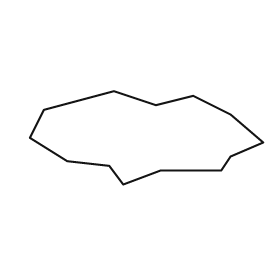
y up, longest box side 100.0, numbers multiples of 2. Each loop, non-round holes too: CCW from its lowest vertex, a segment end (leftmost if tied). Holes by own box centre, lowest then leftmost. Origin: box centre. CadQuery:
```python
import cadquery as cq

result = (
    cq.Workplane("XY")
    .moveTo(-10.0, -20.0)
    .lineTo(6.0, -14.0)
    .lineTo(32.0, -14.0)
    .lineTo(36.0, -8.0)
    .lineTo(50.0, -2.0)
    .lineTo(36.0, 10.0)
    .lineTo(20.0, 18.0)
    .lineTo(4.0, 14.0)
    .lineTo(-14.0, 20.0)
    .lineTo(-44.0, 12.0)
    .lineTo(-50.0, 0.0)
    .lineTo(-34.0, -10.0)
    .lineTo(-16.0, -12.0)
    .close()
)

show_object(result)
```